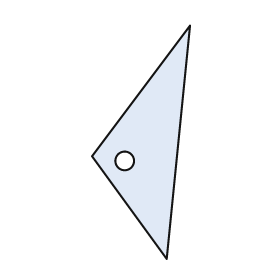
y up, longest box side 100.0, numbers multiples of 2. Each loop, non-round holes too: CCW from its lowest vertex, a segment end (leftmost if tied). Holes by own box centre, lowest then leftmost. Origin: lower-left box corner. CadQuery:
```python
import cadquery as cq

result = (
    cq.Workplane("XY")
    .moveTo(32.0, 0.0)
    .lineTo(42.0, 100.0)
    .lineTo(0.0, 44.0)
    .close()
    .moveTo(14.0, 42.0)
    .circle(4.0)
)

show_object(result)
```